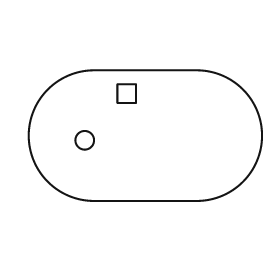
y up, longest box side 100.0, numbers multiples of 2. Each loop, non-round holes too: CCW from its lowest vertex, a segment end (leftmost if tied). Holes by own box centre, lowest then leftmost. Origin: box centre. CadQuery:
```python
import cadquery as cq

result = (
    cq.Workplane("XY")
    .moveTo(-22.0, -28.0)
    .lineTo(22.0, -28.0)
    .threePointArc((50.0, 0.0), (22.0, 28.0))
    .lineTo(-22.0, 28.0)
    .threePointArc((-50.0, 0.0), (-22.0, -28.0))
    .close()
    .moveTo(-26.0, -2.0)
    .circle(4.0)
    .moveTo(-12.0, 14.0)
    .lineTo(-4.0, 14.0)
    .lineTo(-4.0, 22.0)
    .lineTo(-12.0, 22.0)
    .close()
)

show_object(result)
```